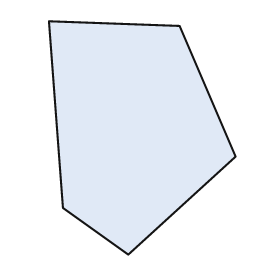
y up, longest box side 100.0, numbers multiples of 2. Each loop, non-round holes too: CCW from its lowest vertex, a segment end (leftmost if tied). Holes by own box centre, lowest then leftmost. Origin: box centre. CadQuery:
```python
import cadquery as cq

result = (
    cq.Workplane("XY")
    .moveTo(-6.0, -50.0)
    .lineTo(40.0, -8.0)
    .lineTo(16.0, 48.0)
    .lineTo(-40.0, 50.0)
    .lineTo(-34.0, -30.0)
    .close()
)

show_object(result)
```